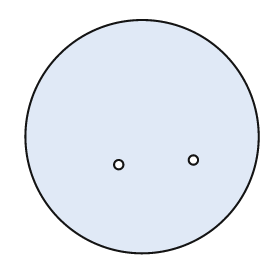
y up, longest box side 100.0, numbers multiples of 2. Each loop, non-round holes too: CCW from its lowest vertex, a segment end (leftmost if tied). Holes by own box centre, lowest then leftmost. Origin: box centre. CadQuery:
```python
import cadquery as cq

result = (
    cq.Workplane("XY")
    .moveTo(0.0, 0.0)
    .circle(50.0)
    .moveTo(-10.0, -12.0)
    .circle(2.0)
    .moveTo(22.0, -10.0)
    .circle(2.0)
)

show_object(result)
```